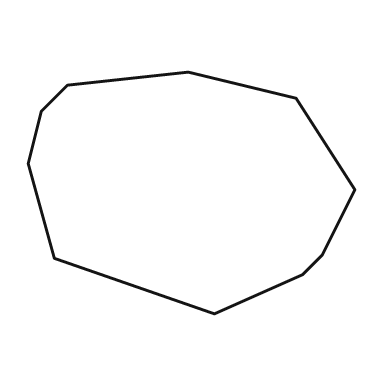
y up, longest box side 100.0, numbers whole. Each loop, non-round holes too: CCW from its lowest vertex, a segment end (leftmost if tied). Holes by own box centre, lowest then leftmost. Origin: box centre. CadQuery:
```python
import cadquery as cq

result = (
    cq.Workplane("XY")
    .moveTo(7.0, -37.0)
    .lineTo(34.0, -25.0)
    .lineTo(40.0, -19.0)
    .lineTo(50.0, 1.0)
    .lineTo(32.0, 29.0)
    .lineTo(-1.0, 37.0)
    .lineTo(-38.0, 33.0)
    .lineTo(-46.0, 25.0)
    .lineTo(-50.0, 9.0)
    .lineTo(-42.0, -20.0)
    .close()
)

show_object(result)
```